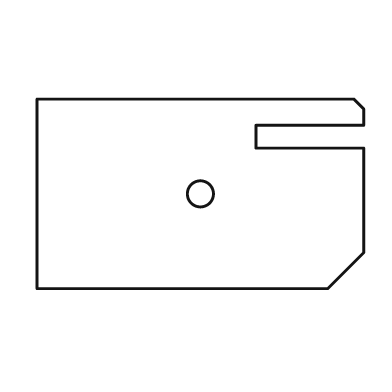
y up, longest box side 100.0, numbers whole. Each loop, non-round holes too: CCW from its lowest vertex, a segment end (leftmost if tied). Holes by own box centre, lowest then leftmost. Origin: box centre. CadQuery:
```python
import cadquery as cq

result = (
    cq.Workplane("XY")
    .moveTo(-50.0, -29.0)
    .lineTo(39.0, -29.0)
    .lineTo(50.0, -18.0)
    .lineTo(50.0, 14.0)
    .lineTo(17.0, 14.0)
    .lineTo(17.0, 21.0)
    .lineTo(50.0, 21.0)
    .lineTo(50.0, 26.0)
    .lineTo(47.0, 29.0)
    .lineTo(-50.0, 29.0)
    .close()
    .moveTo(0.0, 0.0)
    .circle(4.0)
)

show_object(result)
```